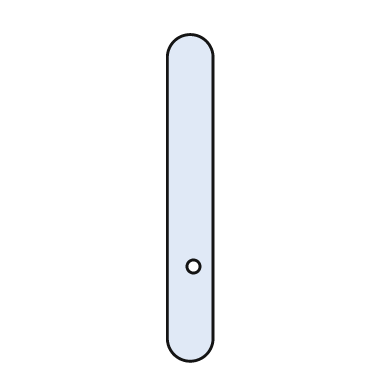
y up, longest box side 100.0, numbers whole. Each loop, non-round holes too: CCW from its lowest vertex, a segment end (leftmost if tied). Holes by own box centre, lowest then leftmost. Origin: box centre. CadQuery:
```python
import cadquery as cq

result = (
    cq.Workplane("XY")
    .moveTo(-7.0, -43.0)
    .threePointArc((0.0, -50.0), (7.0, -43.0))
    .lineTo(7.0, 43.0)
    .threePointArc((0.0, 50.0), (-7.0, 43.0))
    .close()
    .moveTo(1.0, -21.0)
    .circle(2.0)
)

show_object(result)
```